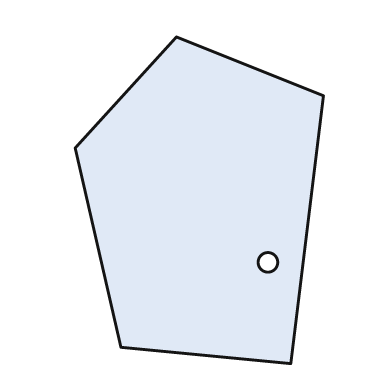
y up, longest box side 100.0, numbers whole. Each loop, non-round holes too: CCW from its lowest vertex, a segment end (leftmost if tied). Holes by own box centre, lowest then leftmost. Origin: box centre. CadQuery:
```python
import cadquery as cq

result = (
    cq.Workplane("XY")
    .moveTo(28.0, -50.0)
    .lineTo(38.0, 32.0)
    .lineTo(-7.0, 50.0)
    .lineTo(-38.0, 16.0)
    .lineTo(-24.0, -45.0)
    .close()
    .moveTo(21.0, -19.0)
    .circle(3.0)
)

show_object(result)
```